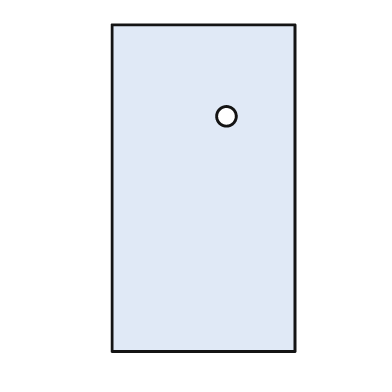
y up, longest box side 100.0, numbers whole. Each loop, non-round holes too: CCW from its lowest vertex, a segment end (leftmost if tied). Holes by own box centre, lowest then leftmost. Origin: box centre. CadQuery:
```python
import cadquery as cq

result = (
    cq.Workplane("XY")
    .moveTo(-28.0, -50.0)
    .lineTo(28.0, -50.0)
    .lineTo(28.0, 50.0)
    .lineTo(-28.0, 50.0)
    .close()
    .moveTo(7.0, 22.0)
    .circle(3.0)
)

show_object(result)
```